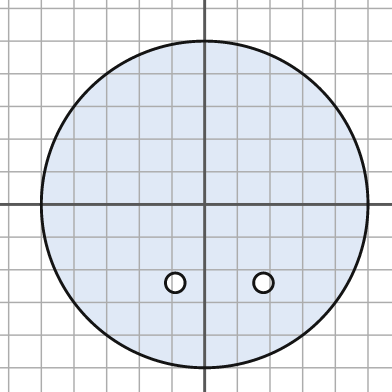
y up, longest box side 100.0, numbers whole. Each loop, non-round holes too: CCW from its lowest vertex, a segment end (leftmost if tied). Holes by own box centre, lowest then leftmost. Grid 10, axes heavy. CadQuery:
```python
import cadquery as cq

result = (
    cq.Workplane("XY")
    .moveTo(0.0, 0.0)
    .circle(50.0)
    .moveTo(-9.0, -24.0)
    .circle(3.0)
    .moveTo(18.0, -24.0)
    .circle(3.0)
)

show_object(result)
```